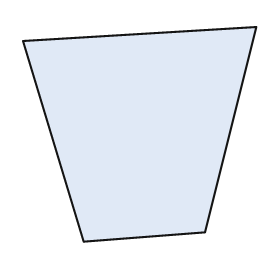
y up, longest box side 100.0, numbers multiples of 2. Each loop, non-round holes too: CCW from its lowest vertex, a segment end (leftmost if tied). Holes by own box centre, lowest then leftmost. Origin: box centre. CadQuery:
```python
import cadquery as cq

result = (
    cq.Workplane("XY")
    .moveTo(-24.0, -46.0)
    .lineTo(28.0, -42.0)
    .lineTo(50.0, 46.0)
    .lineTo(-50.0, 40.0)
    .close()
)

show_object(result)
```